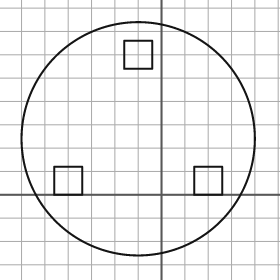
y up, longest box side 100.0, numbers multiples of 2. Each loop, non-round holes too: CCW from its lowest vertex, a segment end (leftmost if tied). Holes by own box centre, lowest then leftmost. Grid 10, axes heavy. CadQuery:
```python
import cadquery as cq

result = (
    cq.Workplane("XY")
    .moveTo(-10.0, 24.0)
    .circle(50.0)
    .moveTo(-46.0, 0.0)
    .lineTo(-34.0, 0.0)
    .lineTo(-34.0, 12.0)
    .lineTo(-46.0, 12.0)
    .close()
    .moveTo(14.0, 0.0)
    .lineTo(26.0, 0.0)
    .lineTo(26.0, 12.0)
    .lineTo(14.0, 12.0)
    .close()
    .moveTo(-16.0, 54.0)
    .lineTo(-4.0, 54.0)
    .lineTo(-4.0, 66.0)
    .lineTo(-16.0, 66.0)
    .close()
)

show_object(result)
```